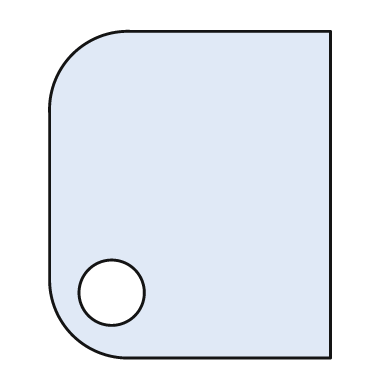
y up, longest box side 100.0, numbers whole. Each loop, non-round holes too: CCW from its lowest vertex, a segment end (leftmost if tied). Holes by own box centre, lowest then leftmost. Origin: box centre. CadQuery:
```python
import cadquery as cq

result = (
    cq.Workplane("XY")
    .moveTo(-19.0, -50.0)
    .lineTo(43.0, -50.0)
    .lineTo(43.0, 50.0)
    .lineTo(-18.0, 50.0)
    .threePointArc((-36.0, 43.0), (-43.0, 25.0))
    .lineTo(-43.0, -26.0)
    .threePointArc((-36.0, -43.0), (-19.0, -50.0))
    .close()
    .moveTo(-24.0, -30.0)
    .circle(10.0)
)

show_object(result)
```